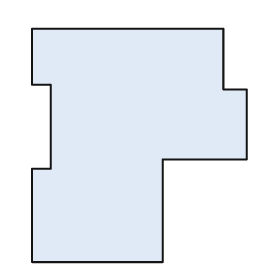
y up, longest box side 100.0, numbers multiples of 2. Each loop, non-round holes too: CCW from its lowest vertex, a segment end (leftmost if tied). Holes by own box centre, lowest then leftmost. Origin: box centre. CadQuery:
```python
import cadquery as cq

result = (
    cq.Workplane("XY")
    .moveTo(-46.0, -50.0)
    .lineTo(10.0, -50.0)
    .lineTo(10.0, -6.0)
    .lineTo(46.0, -6.0)
    .lineTo(46.0, 24.0)
    .lineTo(36.0, 24.0)
    .lineTo(36.0, 50.0)
    .lineTo(-46.0, 50.0)
    .lineTo(-46.0, 26.0)
    .lineTo(-38.0, 26.0)
    .lineTo(-38.0, -10.0)
    .lineTo(-46.0, -10.0)
    .close()
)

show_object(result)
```